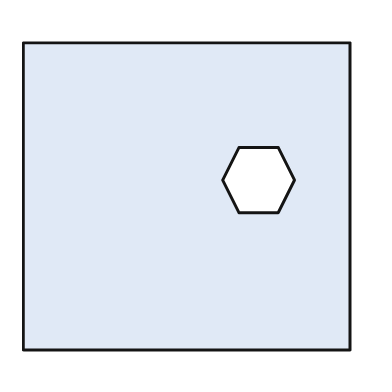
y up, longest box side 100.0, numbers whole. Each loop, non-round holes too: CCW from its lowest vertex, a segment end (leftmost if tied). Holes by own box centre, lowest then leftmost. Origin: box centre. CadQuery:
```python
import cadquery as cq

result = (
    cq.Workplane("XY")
    .moveTo(-50.0, -47.0)
    .lineTo(50.0, -47.0)
    .lineTo(50.0, 47.0)
    .lineTo(-50.0, 47.0)
    .close()
    .moveTo(16.0, -5.0)
    .lineTo(28.0, -5.0)
    .lineTo(33.0, 5.0)
    .lineTo(28.0, 15.0)
    .lineTo(16.0, 15.0)
    .lineTo(11.0, 5.0)
    .close()
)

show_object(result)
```